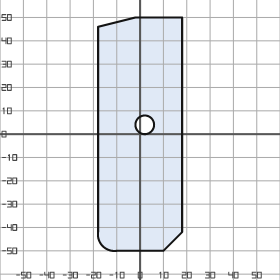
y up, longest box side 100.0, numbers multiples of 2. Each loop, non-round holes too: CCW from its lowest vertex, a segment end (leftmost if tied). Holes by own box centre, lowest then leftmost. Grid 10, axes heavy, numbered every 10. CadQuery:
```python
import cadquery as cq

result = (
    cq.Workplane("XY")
    .moveTo(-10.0, -50.0)
    .lineTo(10.0, -50.0)
    .lineTo(18.0, -42.0)
    .lineTo(18.0, 50.0)
    .lineTo(-2.0, 50.0)
    .lineTo(-18.0, 46.0)
    .lineTo(-18.0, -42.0)
    .threePointArc((-16.0, -48.0), (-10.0, -50.0))
    .close()
    .moveTo(2.0, 4.0)
    .circle(4.0)
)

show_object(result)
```